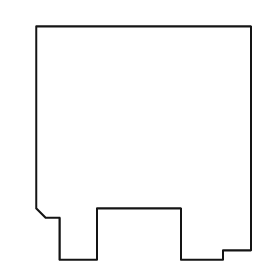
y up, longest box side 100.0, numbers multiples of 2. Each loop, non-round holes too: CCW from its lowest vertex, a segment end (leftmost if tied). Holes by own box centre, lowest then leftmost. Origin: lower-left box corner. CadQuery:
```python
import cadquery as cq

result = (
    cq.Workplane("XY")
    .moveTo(10.0, 0.0)
    .lineTo(26.0, 0.0)
    .lineTo(26.0, 22.0)
    .lineTo(62.0, 22.0)
    .lineTo(62.0, 0.0)
    .lineTo(80.0, 0.0)
    .lineTo(80.0, 4.0)
    .lineTo(92.0, 4.0)
    .lineTo(92.0, 100.0)
    .lineTo(0.0, 100.0)
    .lineTo(0.0, 22.0)
    .lineTo(4.0, 18.0)
    .lineTo(10.0, 18.0)
    .close()
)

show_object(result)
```